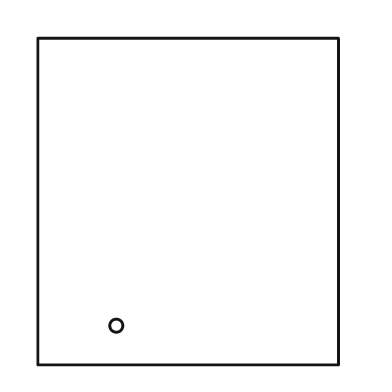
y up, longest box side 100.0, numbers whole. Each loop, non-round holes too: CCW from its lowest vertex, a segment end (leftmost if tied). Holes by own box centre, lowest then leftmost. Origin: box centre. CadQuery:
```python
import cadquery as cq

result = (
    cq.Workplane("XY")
    .moveTo(-46.0, -50.0)
    .lineTo(46.0, -50.0)
    .lineTo(46.0, 50.0)
    .lineTo(-46.0, 50.0)
    .close()
    .moveTo(-22.0, -38.0)
    .circle(2.0)
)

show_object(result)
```